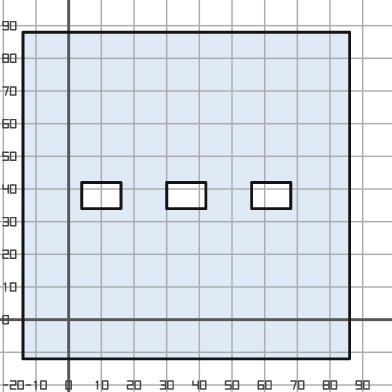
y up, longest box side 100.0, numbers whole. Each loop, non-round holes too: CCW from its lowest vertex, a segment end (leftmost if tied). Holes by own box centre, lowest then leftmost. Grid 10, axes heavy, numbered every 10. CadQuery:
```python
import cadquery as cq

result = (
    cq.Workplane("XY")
    .moveTo(-14.0, -12.0)
    .lineTo(86.0, -12.0)
    .lineTo(86.0, 88.0)
    .lineTo(-14.0, 88.0)
    .close()
    .moveTo(4.0, 34.0)
    .lineTo(16.0, 34.0)
    .lineTo(16.0, 42.0)
    .lineTo(4.0, 42.0)
    .close()
    .moveTo(30.0, 34.0)
    .lineTo(42.0, 34.0)
    .lineTo(42.0, 42.0)
    .lineTo(30.0, 42.0)
    .close()
    .moveTo(56.0, 34.0)
    .lineTo(68.0, 34.0)
    .lineTo(68.0, 42.0)
    .lineTo(56.0, 42.0)
    .close()
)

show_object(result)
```